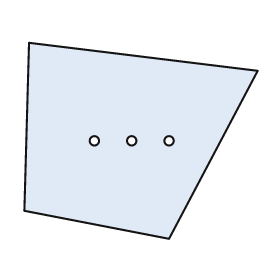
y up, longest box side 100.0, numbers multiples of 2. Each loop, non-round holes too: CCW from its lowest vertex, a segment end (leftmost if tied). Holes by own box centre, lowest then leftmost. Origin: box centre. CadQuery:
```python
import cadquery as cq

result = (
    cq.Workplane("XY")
    .moveTo(12.0, -42.0)
    .lineTo(50.0, 30.0)
    .lineTo(-48.0, 42.0)
    .lineTo(-50.0, -30.0)
    .close()
    .moveTo(-20.0, 0.0)
    .circle(2.0)
    .moveTo(-4.0, 0.0)
    .circle(2.0)
    .moveTo(12.0, 0.0)
    .circle(2.0)
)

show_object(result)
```